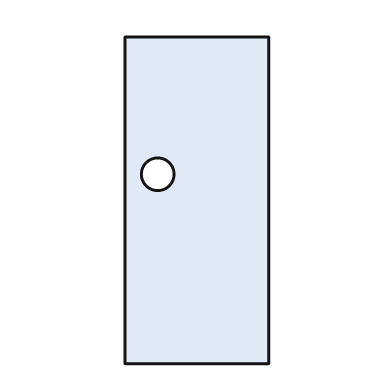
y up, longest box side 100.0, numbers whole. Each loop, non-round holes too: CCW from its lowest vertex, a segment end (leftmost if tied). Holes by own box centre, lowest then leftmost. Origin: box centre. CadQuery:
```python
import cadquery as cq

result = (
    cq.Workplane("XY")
    .moveTo(-22.0, -50.0)
    .lineTo(22.0, -50.0)
    .lineTo(22.0, 50.0)
    .lineTo(-22.0, 50.0)
    .close()
    .moveTo(-12.0, 8.0)
    .circle(5.0)
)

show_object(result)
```